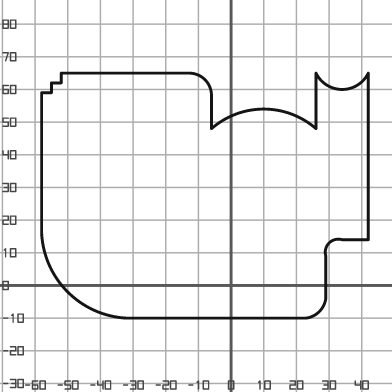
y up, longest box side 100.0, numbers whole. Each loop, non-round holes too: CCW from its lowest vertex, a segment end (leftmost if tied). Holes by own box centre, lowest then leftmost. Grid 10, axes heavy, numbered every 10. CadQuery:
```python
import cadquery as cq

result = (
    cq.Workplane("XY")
    .moveTo(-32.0, -10.0)
    .lineTo(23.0, -10.0)
    .threePointArc((27.0, -8.0), (29.0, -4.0))
    .lineTo(29.0, 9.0)
    .threePointArc((30.0, 13.0), (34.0, 14.0))
    .lineTo(42.0, 14.0)
    .lineTo(42.0, 65.0)
    .threePointArc((34.0, 60.0), (26.0, 65.0))
    .lineTo(26.0, 48.0)
    .threePointArc((10.0, 54.0), (-6.0, 48.0))
    .lineTo(-6.0, 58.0)
    .threePointArc((-8.0, 63.0), (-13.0, 65.0))
    .lineTo(-52.0, 65.0)
    .lineTo(-52.0, 62.0)
    .lineTo(-55.0, 62.0)
    .lineTo(-55.0, 59.0)
    .lineTo(-58.0, 59.0)
    .lineTo(-58.0, 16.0)
    .threePointArc((-50.0, -2.0), (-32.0, -10.0))
    .close()
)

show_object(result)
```